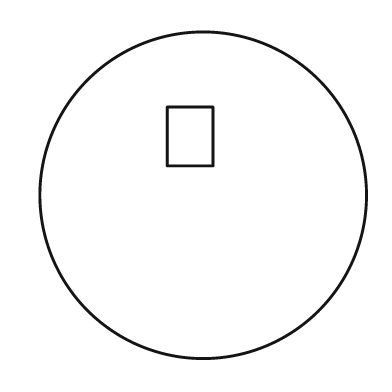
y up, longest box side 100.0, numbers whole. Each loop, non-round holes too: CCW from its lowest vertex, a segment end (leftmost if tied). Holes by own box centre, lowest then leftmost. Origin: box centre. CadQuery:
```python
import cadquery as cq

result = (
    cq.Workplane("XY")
    .moveTo(0.0, 0.0)
    .circle(50.0)
    .moveTo(-11.0, 9.0)
    .lineTo(3.0, 9.0)
    .lineTo(3.0, 27.0)
    .lineTo(-11.0, 27.0)
    .close()
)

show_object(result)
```